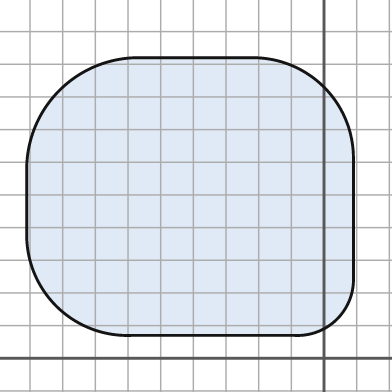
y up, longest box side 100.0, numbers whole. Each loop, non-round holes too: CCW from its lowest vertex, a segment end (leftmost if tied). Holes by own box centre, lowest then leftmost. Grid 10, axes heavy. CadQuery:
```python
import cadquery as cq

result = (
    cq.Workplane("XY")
    .moveTo(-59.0, 7.0)
    .lineTo(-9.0, 7.0)
    .threePointArc((4.0, 12.0), (9.0, 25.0))
    .lineTo(9.0, 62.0)
    .threePointArc((0.0, 83.0), (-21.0, 92.0))
    .lineTo(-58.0, 92.0)
    .threePointArc((-81.0, 82.0), (-91.0, 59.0))
    .lineTo(-91.0, 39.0)
    .threePointArc((-82.0, 16.0), (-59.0, 7.0))
    .close()
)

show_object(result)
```